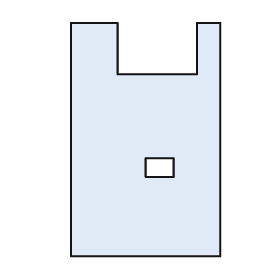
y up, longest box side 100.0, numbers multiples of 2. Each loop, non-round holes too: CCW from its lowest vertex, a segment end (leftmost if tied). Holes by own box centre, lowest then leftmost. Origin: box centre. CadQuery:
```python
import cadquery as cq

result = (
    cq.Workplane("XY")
    .moveTo(-32.0, -50.0)
    .lineTo(32.0, -50.0)
    .lineTo(32.0, 50.0)
    .lineTo(22.0, 50.0)
    .lineTo(22.0, 28.0)
    .lineTo(-12.0, 28.0)
    .lineTo(-12.0, 50.0)
    .lineTo(-32.0, 50.0)
    .close()
    .moveTo(0.0, -16.0)
    .lineTo(12.0, -16.0)
    .lineTo(12.0, -8.0)
    .lineTo(0.0, -8.0)
    .close()
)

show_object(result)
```